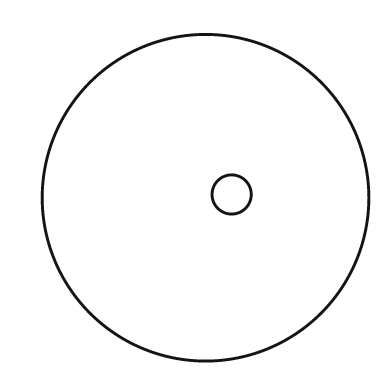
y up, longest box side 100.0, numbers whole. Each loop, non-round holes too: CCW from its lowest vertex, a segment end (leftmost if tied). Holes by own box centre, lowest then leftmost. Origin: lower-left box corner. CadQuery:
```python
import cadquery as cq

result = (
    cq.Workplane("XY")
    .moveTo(50.0, 50.0)
    .circle(50.0)
    .moveTo(58.0, 51.0)
    .circle(6.0)
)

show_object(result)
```